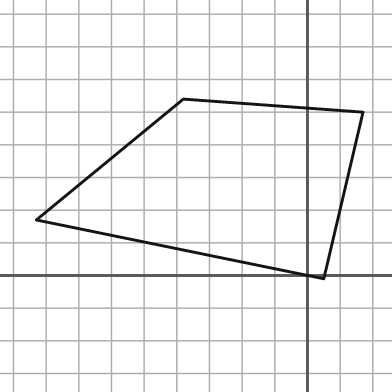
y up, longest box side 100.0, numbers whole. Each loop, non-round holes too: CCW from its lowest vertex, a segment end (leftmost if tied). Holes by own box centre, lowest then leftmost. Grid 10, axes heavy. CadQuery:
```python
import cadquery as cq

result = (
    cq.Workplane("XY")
    .moveTo(5.0, -1.0)
    .lineTo(17.0, 50.0)
    .lineTo(-38.0, 54.0)
    .lineTo(-83.0, 17.0)
    .close()
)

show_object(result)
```